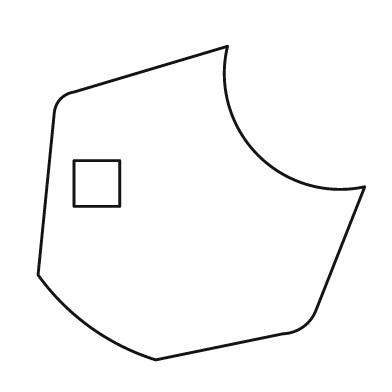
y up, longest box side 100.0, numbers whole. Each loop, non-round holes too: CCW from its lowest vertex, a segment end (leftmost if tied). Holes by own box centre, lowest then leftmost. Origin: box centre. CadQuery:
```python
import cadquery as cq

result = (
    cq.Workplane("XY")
    .moveTo(-14.0, -48.0)
    .lineTo(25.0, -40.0)
    .threePointArc((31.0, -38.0), (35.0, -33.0))
    .lineTo(50.0, 5.0)
    .threePointArc((17.0, 15.0), (8.0, 48.0))
    .lineTo(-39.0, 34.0)
    .threePointArc((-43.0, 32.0), (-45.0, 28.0))
    .lineTo(-50.0, -22.0)
    .threePointArc((-34.0, -38.0), (-14.0, -48.0))
    .close()
    .moveTo(-39.0, -1.0)
    .lineTo(-25.0, -1.0)
    .lineTo(-25.0, 13.0)
    .lineTo(-39.0, 13.0)
    .close()
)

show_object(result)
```